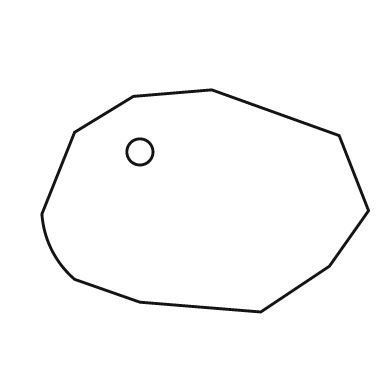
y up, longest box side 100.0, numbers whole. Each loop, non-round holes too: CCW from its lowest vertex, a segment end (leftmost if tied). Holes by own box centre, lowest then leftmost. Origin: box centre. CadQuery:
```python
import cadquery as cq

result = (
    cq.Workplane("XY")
    .moveTo(17.0, -34.0)
    .lineTo(38.0, -20.0)
    .lineTo(50.0, -3.0)
    .lineTo(41.0, 20.0)
    .lineTo(2.0, 34.0)
    .lineTo(-22.0, 32.0)
    .lineTo(-40.0, 21.0)
    .lineTo(-50.0, -4.0)
    .threePointArc((-47.0, -15.0), (-40.0, -24.0))
    .lineTo(-20.0, -31.0)
    .close()
    .moveTo(-20.0, 15.0)
    .circle(4.0)
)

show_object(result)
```